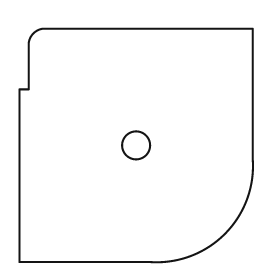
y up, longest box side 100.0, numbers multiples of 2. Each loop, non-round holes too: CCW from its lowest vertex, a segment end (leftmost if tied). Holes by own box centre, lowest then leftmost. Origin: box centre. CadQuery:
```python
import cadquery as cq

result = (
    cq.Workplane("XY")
    .moveTo(-50.0, -50.0)
    .lineTo(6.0, -50.0)
    .threePointArc((38.0, -38.0), (50.0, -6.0))
    .lineTo(50.0, 50.0)
    .lineTo(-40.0, 50.0)
    .threePointArc((-44.0, 48.0), (-46.0, 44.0))
    .lineTo(-46.0, 24.0)
    .lineTo(-50.0, 24.0)
    .close()
    .moveTo(0.0, 0.0)
    .circle(6.0)
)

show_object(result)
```